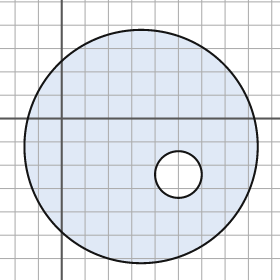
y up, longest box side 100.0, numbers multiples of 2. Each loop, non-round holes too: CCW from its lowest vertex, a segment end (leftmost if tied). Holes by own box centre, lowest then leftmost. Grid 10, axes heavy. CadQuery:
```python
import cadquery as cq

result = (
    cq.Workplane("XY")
    .moveTo(34.0, -12.0)
    .circle(50.0)
    .moveTo(50.0, -24.0)
    .circle(10.0)
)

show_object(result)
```